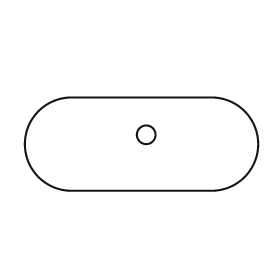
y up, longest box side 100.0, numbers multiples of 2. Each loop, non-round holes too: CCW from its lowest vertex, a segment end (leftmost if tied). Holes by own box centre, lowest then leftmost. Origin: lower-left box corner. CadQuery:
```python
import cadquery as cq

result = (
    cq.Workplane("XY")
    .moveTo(20.0, 0.0)
    .lineTo(80.0, 0.0)
    .threePointArc((100.0, 20.0), (80.0, 40.0))
    .lineTo(20.0, 40.0)
    .threePointArc((0.0, 20.0), (20.0, 0.0))
    .close()
    .moveTo(52.0, 24.0)
    .circle(4.0)
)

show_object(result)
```